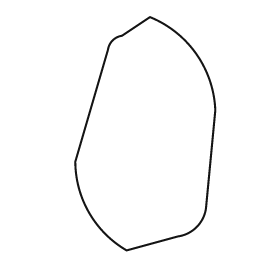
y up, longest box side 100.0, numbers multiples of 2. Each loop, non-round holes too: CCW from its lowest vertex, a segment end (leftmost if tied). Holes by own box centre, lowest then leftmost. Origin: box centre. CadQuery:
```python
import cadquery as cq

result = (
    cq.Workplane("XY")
    .moveTo(-8.0, -50.0)
    .lineTo(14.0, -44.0)
    .threePointArc((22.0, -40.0), (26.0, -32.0))
    .lineTo(30.0, 10.0)
    .threePointArc((22.0, 34.0), (2.0, 50.0))
    .lineTo(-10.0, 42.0)
    .threePointArc((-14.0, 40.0), (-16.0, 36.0))
    .lineTo(-30.0, -12.0)
    .threePointArc((-24.0, -34.0), (-8.0, -50.0))
    .close()
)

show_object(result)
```